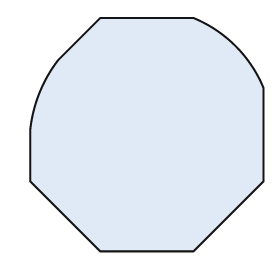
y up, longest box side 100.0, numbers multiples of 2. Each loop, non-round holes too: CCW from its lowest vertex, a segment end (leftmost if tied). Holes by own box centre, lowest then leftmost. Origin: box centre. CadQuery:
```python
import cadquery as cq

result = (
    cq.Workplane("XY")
    .moveTo(-20.0, -50.0)
    .lineTo(20.0, -50.0)
    .lineTo(50.0, -20.0)
    .lineTo(50.0, 20.0)
    .threePointArc((38.0, 38.0), (20.0, 50.0))
    .lineTo(-20.0, 50.0)
    .lineTo(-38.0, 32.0)
    .threePointArc((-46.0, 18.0), (-50.0, 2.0))
    .lineTo(-50.0, -20.0)
    .close()
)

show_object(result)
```